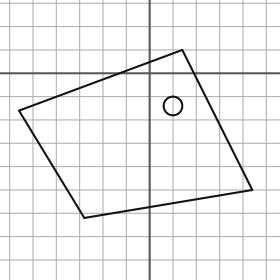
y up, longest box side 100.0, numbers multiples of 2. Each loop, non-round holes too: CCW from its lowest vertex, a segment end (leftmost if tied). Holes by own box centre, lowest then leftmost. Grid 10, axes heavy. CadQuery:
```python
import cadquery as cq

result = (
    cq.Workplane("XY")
    .moveTo(-28.0, -62.0)
    .lineTo(44.0, -50.0)
    .lineTo(14.0, 10.0)
    .lineTo(-56.0, -16.0)
    .close()
    .moveTo(10.0, -14.0)
    .circle(4.0)
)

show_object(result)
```